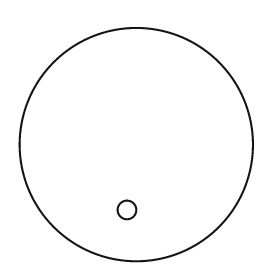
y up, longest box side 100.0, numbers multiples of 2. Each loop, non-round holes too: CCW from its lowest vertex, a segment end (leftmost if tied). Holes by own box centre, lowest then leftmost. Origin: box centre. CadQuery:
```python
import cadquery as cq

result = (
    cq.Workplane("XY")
    .moveTo(0.0, 0.0)
    .circle(50.0)
    .moveTo(-4.0, -28.0)
    .circle(4.0)
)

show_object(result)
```